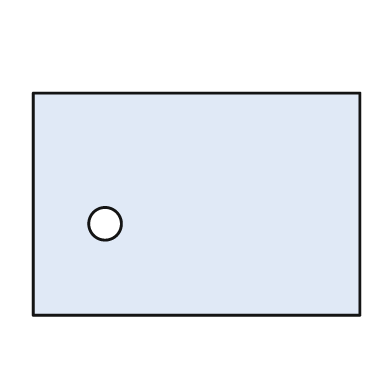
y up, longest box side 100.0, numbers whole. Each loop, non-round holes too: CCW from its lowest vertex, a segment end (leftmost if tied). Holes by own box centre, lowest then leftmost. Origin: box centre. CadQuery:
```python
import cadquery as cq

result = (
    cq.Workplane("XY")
    .moveTo(-50.0, -34.0)
    .lineTo(50.0, -34.0)
    .lineTo(50.0, 34.0)
    .lineTo(-50.0, 34.0)
    .close()
    .moveTo(-28.0, -6.0)
    .circle(5.0)
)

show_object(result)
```